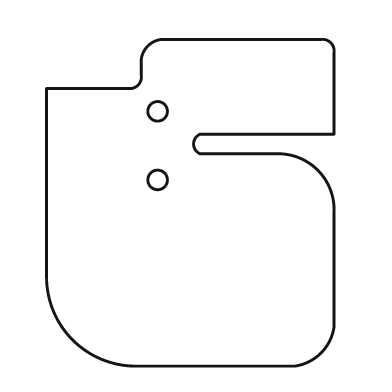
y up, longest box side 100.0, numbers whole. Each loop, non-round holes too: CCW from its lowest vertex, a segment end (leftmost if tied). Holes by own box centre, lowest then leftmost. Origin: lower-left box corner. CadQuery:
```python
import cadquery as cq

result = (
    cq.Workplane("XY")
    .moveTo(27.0, 0.0)
    .lineTo(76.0, 0.0)
    .threePointArc((84.0, 4.0), (88.0, 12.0))
    .lineTo(88.0, 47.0)
    .threePointArc((83.0, 60.0), (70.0, 65.0))
    .lineTo(47.0, 65.0)
    .threePointArc((45.0, 68.0), (47.0, 71.0))
    .lineTo(88.0, 71.0)
    .lineTo(88.0, 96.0)
    .threePointArc((87.0, 99.0), (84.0, 100.0))
    .lineTo(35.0, 100.0)
    .threePointArc((31.0, 98.0), (29.0, 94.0))
    .lineTo(29.0, 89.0)
    .threePointArc((28.0, 86.0), (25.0, 85.0))
    .lineTo(0.0, 85.0)
    .lineTo(0.0, 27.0)
    .threePointArc((8.0, 8.0), (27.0, 0.0))
    .close()
    .moveTo(34.0, 57.0)
    .circle(3.0)
    .moveTo(34.0, 78.0)
    .circle(3.0)
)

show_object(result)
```